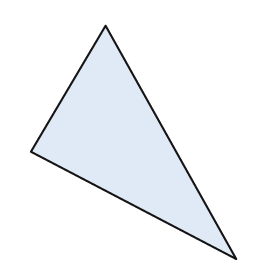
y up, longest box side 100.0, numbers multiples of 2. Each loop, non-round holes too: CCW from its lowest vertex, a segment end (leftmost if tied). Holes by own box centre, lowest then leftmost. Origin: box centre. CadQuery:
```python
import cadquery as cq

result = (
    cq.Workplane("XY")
    .moveTo(44.0, -50.0)
    .lineTo(-12.0, 50.0)
    .lineTo(-44.0, -4.0)
    .close()
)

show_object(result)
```